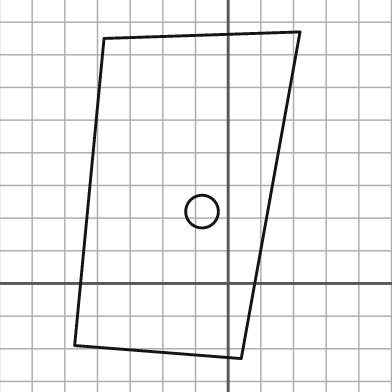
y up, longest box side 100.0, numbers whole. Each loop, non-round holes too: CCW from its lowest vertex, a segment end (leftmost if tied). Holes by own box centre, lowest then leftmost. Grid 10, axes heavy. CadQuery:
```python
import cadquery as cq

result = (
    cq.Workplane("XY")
    .moveTo(4.0, -23.0)
    .lineTo(22.0, 77.0)
    .lineTo(-38.0, 75.0)
    .lineTo(-47.0, -19.0)
    .close()
    .moveTo(-8.0, 22.0)
    .circle(5.0)
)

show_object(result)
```